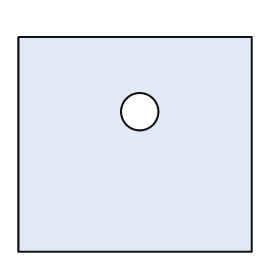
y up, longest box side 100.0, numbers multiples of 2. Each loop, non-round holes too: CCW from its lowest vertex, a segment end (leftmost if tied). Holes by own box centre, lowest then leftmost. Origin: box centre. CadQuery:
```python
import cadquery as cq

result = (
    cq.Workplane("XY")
    .moveTo(-50.0, -46.0)
    .lineTo(50.0, -46.0)
    .lineTo(50.0, 46.0)
    .lineTo(-50.0, 46.0)
    .close()
    .moveTo(2.0, 14.0)
    .circle(8.0)
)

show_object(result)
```